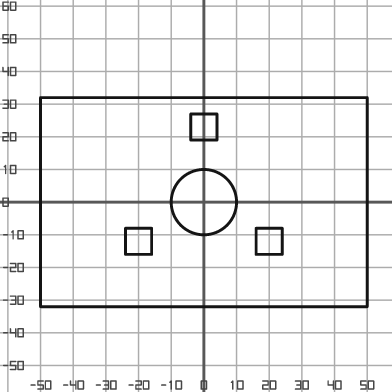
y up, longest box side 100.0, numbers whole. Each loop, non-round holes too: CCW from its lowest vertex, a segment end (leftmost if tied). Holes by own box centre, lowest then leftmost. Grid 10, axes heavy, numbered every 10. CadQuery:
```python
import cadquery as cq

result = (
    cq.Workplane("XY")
    .moveTo(-50.0, -32.0)
    .lineTo(50.0, -32.0)
    .lineTo(50.0, 32.0)
    .lineTo(-50.0, 32.0)
    .close()
    .moveTo(-24.0, -16.0)
    .lineTo(-16.0, -16.0)
    .lineTo(-16.0, -8.0)
    .lineTo(-24.0, -8.0)
    .close()
    .moveTo(16.0, -16.0)
    .lineTo(24.0, -16.0)
    .lineTo(24.0, -8.0)
    .lineTo(16.0, -8.0)
    .close()
    .moveTo(0.0, 0.0)
    .circle(10.0)
    .moveTo(-4.0, 19.0)
    .lineTo(4.0, 19.0)
    .lineTo(4.0, 27.0)
    .lineTo(-4.0, 27.0)
    .close()
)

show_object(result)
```